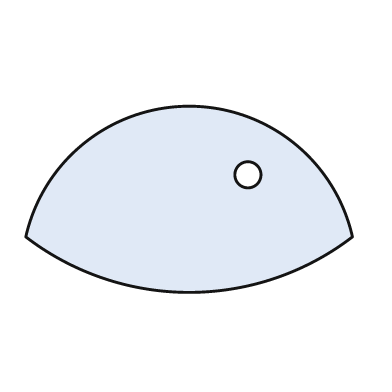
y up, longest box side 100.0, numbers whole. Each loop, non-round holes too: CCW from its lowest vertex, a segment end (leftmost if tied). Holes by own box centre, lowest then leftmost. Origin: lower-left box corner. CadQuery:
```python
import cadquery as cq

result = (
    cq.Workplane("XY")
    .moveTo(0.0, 17.0)
    .threePointArc((50.0, 0.0), (100.0, 17.0))
    .threePointArc((50.0, 57.0), (0.0, 17.0))
    .close()
    .moveTo(68.0, 36.0)
    .circle(4.0)
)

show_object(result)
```